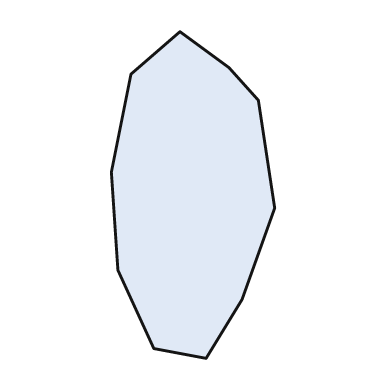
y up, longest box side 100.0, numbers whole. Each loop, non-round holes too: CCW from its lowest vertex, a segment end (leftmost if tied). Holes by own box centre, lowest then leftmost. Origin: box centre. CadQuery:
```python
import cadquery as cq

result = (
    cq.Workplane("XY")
    .moveTo(4.0, -50.0)
    .lineTo(15.0, -32.0)
    .lineTo(25.0, -4.0)
    .lineTo(20.0, 29.0)
    .lineTo(11.0, 39.0)
    .lineTo(-4.0, 50.0)
    .lineTo(-19.0, 37.0)
    .lineTo(-25.0, 7.0)
    .lineTo(-23.0, -23.0)
    .lineTo(-12.0, -47.0)
    .close()
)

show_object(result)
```